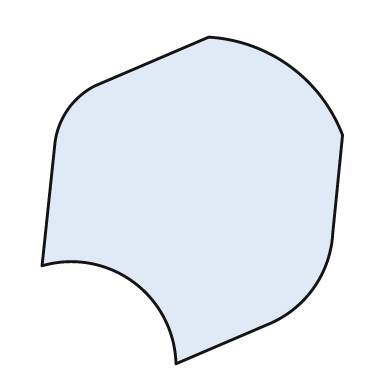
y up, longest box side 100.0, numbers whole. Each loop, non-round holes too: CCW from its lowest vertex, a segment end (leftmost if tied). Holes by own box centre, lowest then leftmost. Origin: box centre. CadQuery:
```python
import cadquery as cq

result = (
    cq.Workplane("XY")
    .moveTo(-5.0, -50.0)
    .lineTo(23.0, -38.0)
    .threePointArc((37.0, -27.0), (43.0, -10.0))
    .lineTo(46.0, 20.0)
    .threePointArc((30.0, 41.0), (5.0, 50.0))
    .lineTo(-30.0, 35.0)
    .threePointArc((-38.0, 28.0), (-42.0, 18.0))
    .lineTo(-46.0, -20.0)
    .threePointArc((-18.0, -25.0), (-5.0, -50.0))
    .close()
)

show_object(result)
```